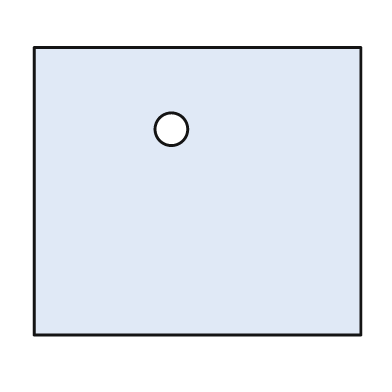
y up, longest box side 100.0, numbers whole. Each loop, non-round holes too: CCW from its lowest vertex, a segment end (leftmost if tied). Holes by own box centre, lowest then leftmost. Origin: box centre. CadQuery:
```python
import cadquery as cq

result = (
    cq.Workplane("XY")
    .moveTo(-50.0, -44.0)
    .lineTo(50.0, -44.0)
    .lineTo(50.0, 44.0)
    .lineTo(-50.0, 44.0)
    .close()
    .moveTo(-8.0, 19.0)
    .circle(5.0)
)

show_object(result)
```